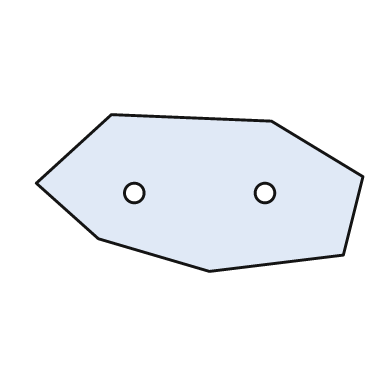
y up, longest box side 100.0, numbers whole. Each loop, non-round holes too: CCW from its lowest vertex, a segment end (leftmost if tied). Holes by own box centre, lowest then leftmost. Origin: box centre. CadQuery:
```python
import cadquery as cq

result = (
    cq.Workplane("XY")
    .moveTo(3.0, -24.0)
    .lineTo(44.0, -19.0)
    .lineTo(50.0, 5.0)
    .lineTo(22.0, 22.0)
    .lineTo(-27.0, 24.0)
    .lineTo(-50.0, 3.0)
    .lineTo(-31.0, -14.0)
    .close()
    .moveTo(-20.0, 0.0)
    .circle(3.0)
    .moveTo(20.0, 0.0)
    .circle(3.0)
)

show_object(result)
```